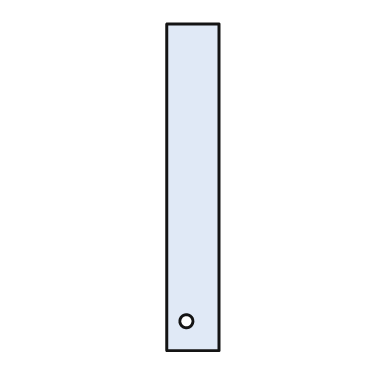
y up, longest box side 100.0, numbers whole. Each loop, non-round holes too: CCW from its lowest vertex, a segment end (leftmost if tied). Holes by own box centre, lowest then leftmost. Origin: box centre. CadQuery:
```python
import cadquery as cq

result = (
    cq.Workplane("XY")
    .moveTo(-8.0, -50.0)
    .lineTo(8.0, -50.0)
    .lineTo(8.0, 50.0)
    .lineTo(-8.0, 50.0)
    .close()
    .moveTo(-2.0, -41.0)
    .circle(2.0)
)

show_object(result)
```